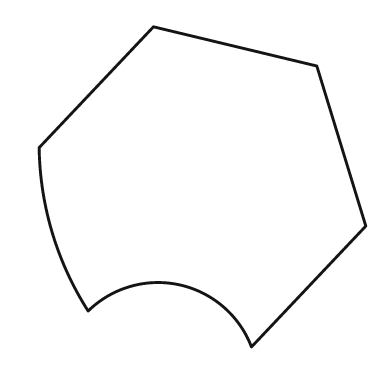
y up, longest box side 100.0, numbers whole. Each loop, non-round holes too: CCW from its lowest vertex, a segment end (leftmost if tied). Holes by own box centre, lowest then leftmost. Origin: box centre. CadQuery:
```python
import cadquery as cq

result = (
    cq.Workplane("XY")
    .moveTo(15.0, -49.0)
    .lineTo(50.0, -12.0)
    .lineTo(35.0, 37.0)
    .lineTo(-15.0, 49.0)
    .lineTo(-50.0, 12.0)
    .threePointArc((-46.0, -14.0), (-35.0, -38.0))
    .threePointArc((-7.0, -30.0), (15.0, -49.0))
    .close()
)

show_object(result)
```